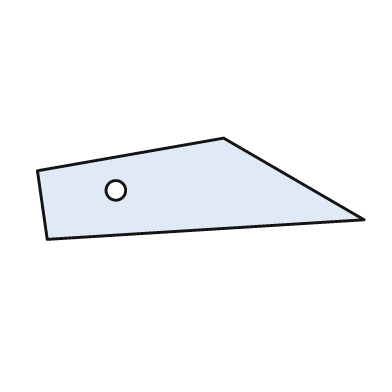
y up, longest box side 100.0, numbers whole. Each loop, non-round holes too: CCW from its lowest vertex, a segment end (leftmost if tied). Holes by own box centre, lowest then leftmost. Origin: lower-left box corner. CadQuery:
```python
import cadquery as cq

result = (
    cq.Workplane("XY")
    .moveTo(3.0, 0.0)
    .lineTo(100.0, 6.0)
    .lineTo(57.0, 31.0)
    .lineTo(0.0, 21.0)
    .close()
    .moveTo(24.0, 15.0)
    .circle(3.0)
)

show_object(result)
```